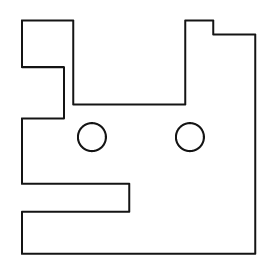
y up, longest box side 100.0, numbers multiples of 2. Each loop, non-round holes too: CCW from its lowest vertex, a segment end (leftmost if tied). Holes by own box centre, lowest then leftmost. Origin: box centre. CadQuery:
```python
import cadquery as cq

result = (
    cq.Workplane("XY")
    .moveTo(-50.0, -50.0)
    .lineTo(50.0, -50.0)
    .lineTo(50.0, 44.0)
    .lineTo(32.0, 44.0)
    .lineTo(32.0, 50.0)
    .lineTo(20.0, 50.0)
    .lineTo(20.0, 14.0)
    .lineTo(-28.0, 14.0)
    .lineTo(-28.0, 50.0)
    .lineTo(-50.0, 50.0)
    .lineTo(-50.0, 30.0)
    .lineTo(-32.0, 30.0)
    .lineTo(-32.0, 8.0)
    .lineTo(-50.0, 8.0)
    .lineTo(-50.0, -20.0)
    .lineTo(-4.0, -20.0)
    .lineTo(-4.0, -32.0)
    .lineTo(-50.0, -32.0)
    .close()
    .moveTo(-20.0, 0.0)
    .circle(6.0)
    .moveTo(22.0, 0.0)
    .circle(6.0)
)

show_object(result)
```